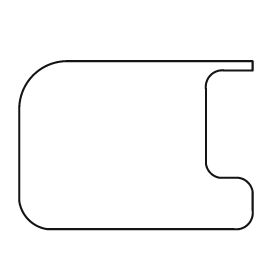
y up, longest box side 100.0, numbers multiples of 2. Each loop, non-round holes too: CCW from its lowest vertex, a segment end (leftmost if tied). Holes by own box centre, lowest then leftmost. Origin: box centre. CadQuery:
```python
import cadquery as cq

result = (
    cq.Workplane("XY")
    .moveTo(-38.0, -36.0)
    .lineTo(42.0, -36.0)
    .threePointArc((48.0, -34.0), (50.0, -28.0))
    .lineTo(50.0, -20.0)
    .threePointArc((48.0, -16.0), (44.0, -14.0))
    .lineTo(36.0, -14.0)
    .threePointArc((32.0, -12.0), (30.0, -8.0))
    .lineTo(30.0, 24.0)
    .threePointArc((32.0, 30.0), (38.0, 32.0))
    .lineTo(50.0, 32.0)
    .lineTo(50.0, 36.0)
    .lineTo(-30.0, 36.0)
    .threePointArc((-44.0, 30.0), (-50.0, 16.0))
    .lineTo(-50.0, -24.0)
    .threePointArc((-46.0, -32.0), (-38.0, -36.0))
    .close()
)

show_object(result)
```